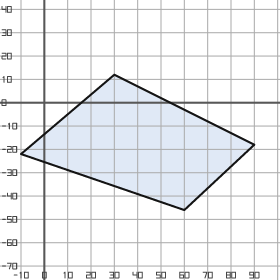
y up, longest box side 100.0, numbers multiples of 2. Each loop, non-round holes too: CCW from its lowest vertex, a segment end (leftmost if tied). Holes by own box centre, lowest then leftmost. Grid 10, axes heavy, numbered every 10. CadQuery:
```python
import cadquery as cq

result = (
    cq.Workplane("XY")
    .moveTo(60.0, -46.0)
    .lineTo(90.0, -18.0)
    .lineTo(30.0, 12.0)
    .lineTo(-10.0, -22.0)
    .close()
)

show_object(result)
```